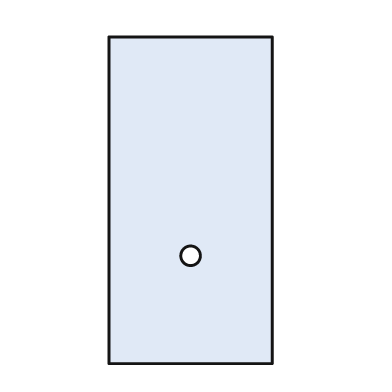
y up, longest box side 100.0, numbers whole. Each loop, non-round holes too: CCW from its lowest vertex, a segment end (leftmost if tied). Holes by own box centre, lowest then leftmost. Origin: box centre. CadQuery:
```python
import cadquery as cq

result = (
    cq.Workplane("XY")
    .moveTo(-25.0, -50.0)
    .lineTo(25.0, -50.0)
    .lineTo(25.0, 50.0)
    .lineTo(-25.0, 50.0)
    .close()
    .moveTo(0.0, -17.0)
    .circle(3.0)
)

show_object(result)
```